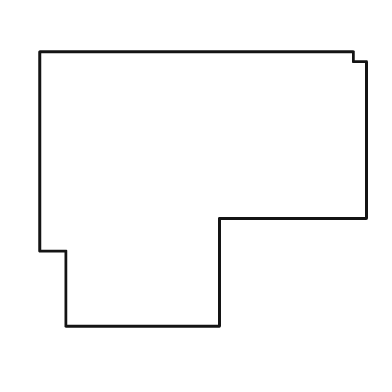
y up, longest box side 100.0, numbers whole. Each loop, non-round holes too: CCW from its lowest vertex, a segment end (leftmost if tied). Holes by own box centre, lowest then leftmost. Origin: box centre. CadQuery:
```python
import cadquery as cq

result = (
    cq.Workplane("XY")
    .moveTo(-42.0, -42.0)
    .lineTo(5.0, -42.0)
    .lineTo(5.0, -9.0)
    .lineTo(50.0, -9.0)
    .lineTo(50.0, 39.0)
    .lineTo(46.0, 39.0)
    .lineTo(46.0, 42.0)
    .lineTo(-50.0, 42.0)
    .lineTo(-50.0, -19.0)
    .lineTo(-42.0, -19.0)
    .close()
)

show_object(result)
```